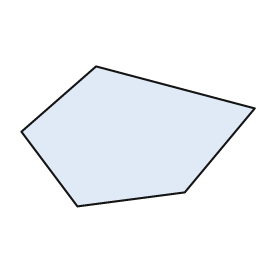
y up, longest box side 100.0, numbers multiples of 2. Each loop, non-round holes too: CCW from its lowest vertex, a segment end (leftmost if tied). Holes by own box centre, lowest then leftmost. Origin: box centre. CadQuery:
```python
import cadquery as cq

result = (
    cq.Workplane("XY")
    .moveTo(-26.0, -30.0)
    .lineTo(20.0, -24.0)
    .lineTo(50.0, 12.0)
    .lineTo(-18.0, 30.0)
    .lineTo(-50.0, 2.0)
    .close()
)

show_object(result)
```